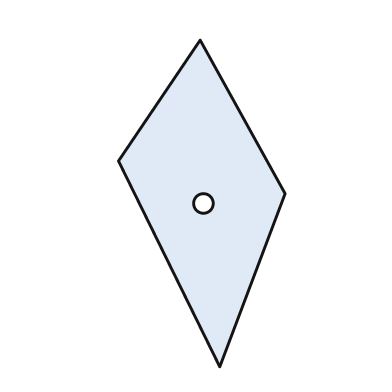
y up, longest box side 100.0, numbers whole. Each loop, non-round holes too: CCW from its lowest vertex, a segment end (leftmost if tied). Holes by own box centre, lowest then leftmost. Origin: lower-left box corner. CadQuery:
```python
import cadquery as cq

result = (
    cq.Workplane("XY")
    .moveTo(31.0, 0.0)
    .lineTo(51.0, 53.0)
    .lineTo(25.0, 100.0)
    .lineTo(0.0, 63.0)
    .close()
    .moveTo(26.0, 50.0)
    .circle(3.0)
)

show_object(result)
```